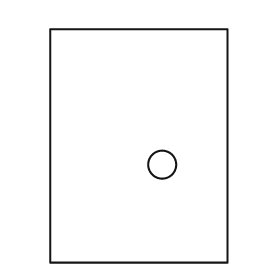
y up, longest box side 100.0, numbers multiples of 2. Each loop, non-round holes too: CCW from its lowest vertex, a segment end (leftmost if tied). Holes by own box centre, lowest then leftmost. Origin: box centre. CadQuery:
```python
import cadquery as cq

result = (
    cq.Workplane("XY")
    .moveTo(-38.0, -50.0)
    .lineTo(38.0, -50.0)
    .lineTo(38.0, 50.0)
    .lineTo(-38.0, 50.0)
    .close()
    .moveTo(10.0, -8.0)
    .circle(6.0)
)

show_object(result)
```